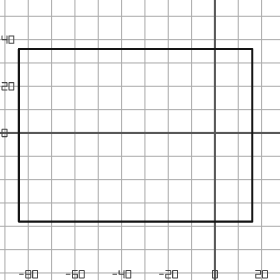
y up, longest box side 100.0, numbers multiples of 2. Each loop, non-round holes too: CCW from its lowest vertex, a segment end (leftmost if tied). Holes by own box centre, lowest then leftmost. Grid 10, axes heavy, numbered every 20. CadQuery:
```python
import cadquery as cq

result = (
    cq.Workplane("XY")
    .moveTo(-84.0, -38.0)
    .lineTo(16.0, -38.0)
    .lineTo(16.0, 36.0)
    .lineTo(-84.0, 36.0)
    .close()
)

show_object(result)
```